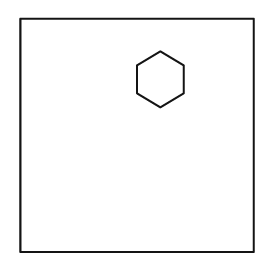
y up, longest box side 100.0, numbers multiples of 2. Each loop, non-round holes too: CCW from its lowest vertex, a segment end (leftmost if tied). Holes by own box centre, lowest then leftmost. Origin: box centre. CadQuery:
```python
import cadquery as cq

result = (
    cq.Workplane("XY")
    .moveTo(-50.0, -50.0)
    .lineTo(50.0, -50.0)
    .lineTo(50.0, 50.0)
    .lineTo(-50.0, 50.0)
    .close()
    .moveTo(10.0, 12.0)
    .lineTo(20.0, 18.0)
    .lineTo(20.0, 30.0)
    .lineTo(10.0, 36.0)
    .lineTo(0.0, 30.0)
    .lineTo(0.0, 18.0)
    .close()
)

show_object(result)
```